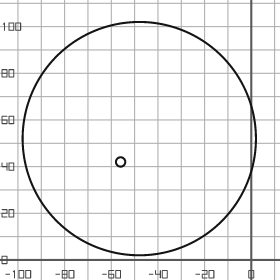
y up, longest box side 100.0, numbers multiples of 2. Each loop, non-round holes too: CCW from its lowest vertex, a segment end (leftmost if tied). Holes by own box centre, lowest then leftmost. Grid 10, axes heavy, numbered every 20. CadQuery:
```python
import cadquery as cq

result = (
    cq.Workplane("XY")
    .moveTo(-48.0, 52.0)
    .circle(50.0)
    .moveTo(-56.0, 42.0)
    .circle(2.0)
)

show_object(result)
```